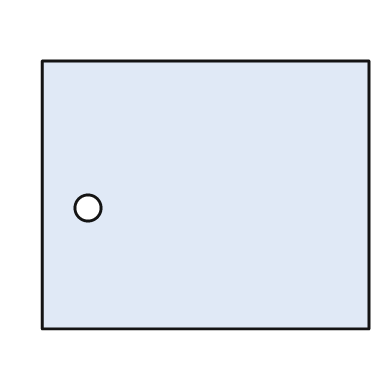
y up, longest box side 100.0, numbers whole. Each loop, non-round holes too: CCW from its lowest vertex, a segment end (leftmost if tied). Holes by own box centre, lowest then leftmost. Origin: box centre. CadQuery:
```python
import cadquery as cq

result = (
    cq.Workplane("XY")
    .moveTo(-50.0, -41.0)
    .lineTo(50.0, -41.0)
    .lineTo(50.0, 41.0)
    .lineTo(-50.0, 41.0)
    .close()
    .moveTo(-36.0, -4.0)
    .circle(4.0)
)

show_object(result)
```